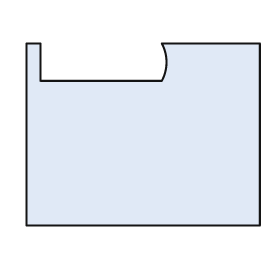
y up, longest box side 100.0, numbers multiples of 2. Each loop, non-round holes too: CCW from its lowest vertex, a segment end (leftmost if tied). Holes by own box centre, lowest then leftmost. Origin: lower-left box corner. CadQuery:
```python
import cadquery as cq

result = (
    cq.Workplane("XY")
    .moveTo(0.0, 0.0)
    .lineTo(100.0, 0.0)
    .lineTo(100.0, 78.0)
    .lineTo(58.0, 78.0)
    .threePointArc((60.0, 70.0), (58.0, 62.0))
    .lineTo(6.0, 62.0)
    .lineTo(6.0, 78.0)
    .lineTo(0.0, 78.0)
    .close()
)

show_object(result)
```